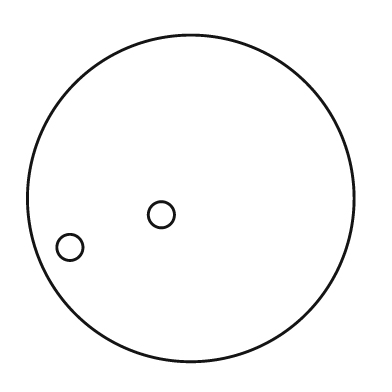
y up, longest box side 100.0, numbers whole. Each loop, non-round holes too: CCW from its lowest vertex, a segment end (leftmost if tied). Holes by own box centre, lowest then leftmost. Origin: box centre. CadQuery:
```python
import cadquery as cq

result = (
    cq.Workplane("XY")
    .moveTo(0.0, 0.0)
    .circle(50.0)
    .moveTo(-37.0, -15.0)
    .circle(4.0)
    .moveTo(-9.0, -5.0)
    .circle(4.0)
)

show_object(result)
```